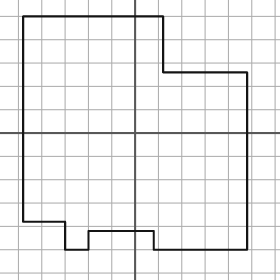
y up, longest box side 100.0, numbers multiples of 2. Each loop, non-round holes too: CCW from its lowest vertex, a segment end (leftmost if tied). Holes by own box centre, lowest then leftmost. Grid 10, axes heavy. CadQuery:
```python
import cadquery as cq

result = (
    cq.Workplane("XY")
    .moveTo(-30.0, -50.0)
    .lineTo(-20.0, -50.0)
    .lineTo(-20.0, -42.0)
    .lineTo(8.0, -42.0)
    .lineTo(8.0, -50.0)
    .lineTo(48.0, -50.0)
    .lineTo(48.0, 26.0)
    .lineTo(12.0, 26.0)
    .lineTo(12.0, 50.0)
    .lineTo(-48.0, 50.0)
    .lineTo(-48.0, -38.0)
    .lineTo(-30.0, -38.0)
    .close()
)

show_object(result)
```